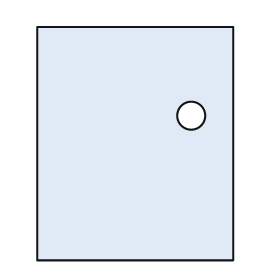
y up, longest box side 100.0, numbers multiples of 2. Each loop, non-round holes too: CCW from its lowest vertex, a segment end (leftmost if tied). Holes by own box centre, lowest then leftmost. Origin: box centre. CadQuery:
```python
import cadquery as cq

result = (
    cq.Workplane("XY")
    .moveTo(-42.0, -50.0)
    .lineTo(42.0, -50.0)
    .lineTo(42.0, 50.0)
    .lineTo(-42.0, 50.0)
    .close()
    .moveTo(24.0, 12.0)
    .circle(6.0)
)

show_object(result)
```